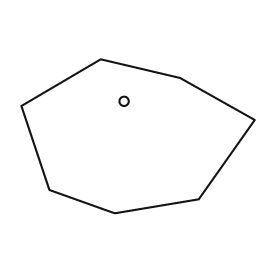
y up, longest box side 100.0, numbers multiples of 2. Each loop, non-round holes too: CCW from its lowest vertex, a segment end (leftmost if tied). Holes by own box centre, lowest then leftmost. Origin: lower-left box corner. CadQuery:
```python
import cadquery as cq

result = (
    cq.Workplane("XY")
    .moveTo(40.0, 0.0)
    .lineTo(76.0, 6.0)
    .lineTo(100.0, 40.0)
    .lineTo(68.0, 58.0)
    .lineTo(34.0, 66.0)
    .lineTo(0.0, 46.0)
    .lineTo(12.0, 10.0)
    .close()
    .moveTo(44.0, 48.0)
    .circle(2.0)
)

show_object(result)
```